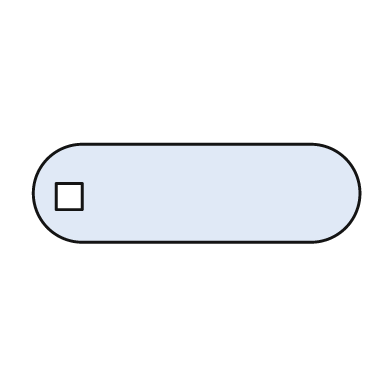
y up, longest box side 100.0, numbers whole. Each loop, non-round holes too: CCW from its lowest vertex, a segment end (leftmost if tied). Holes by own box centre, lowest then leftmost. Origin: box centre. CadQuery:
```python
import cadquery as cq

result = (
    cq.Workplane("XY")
    .moveTo(-35.0, -15.0)
    .lineTo(35.0, -15.0)
    .threePointArc((50.0, 0.0), (35.0, 15.0))
    .lineTo(-35.0, 15.0)
    .threePointArc((-50.0, 0.0), (-35.0, -15.0))
    .close()
    .moveTo(-43.0, -5.0)
    .lineTo(-35.0, -5.0)
    .lineTo(-35.0, 3.0)
    .lineTo(-43.0, 3.0)
    .close()
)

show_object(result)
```